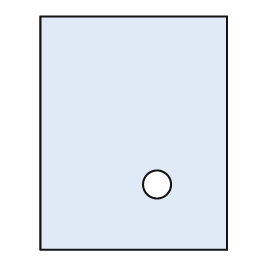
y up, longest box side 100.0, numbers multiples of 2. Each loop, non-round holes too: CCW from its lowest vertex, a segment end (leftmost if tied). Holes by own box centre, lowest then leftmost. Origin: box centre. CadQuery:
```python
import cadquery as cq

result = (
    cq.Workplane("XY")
    .moveTo(-40.0, -50.0)
    .lineTo(40.0, -50.0)
    .lineTo(40.0, 50.0)
    .lineTo(-40.0, 50.0)
    .close()
    .moveTo(10.0, -22.0)
    .circle(6.0)
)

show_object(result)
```